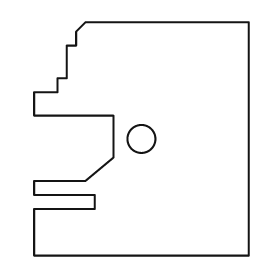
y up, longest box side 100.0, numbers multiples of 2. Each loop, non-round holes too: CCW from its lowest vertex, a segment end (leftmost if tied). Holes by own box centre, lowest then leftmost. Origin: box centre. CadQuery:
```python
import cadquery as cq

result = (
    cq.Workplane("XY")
    .moveTo(-46.0, -50.0)
    .lineTo(46.0, -50.0)
    .lineTo(46.0, 50.0)
    .lineTo(-24.0, 50.0)
    .lineTo(-28.0, 46.0)
    .lineTo(-28.0, 40.0)
    .lineTo(-32.0, 40.0)
    .lineTo(-32.0, 26.0)
    .lineTo(-36.0, 26.0)
    .lineTo(-36.0, 20.0)
    .lineTo(-46.0, 20.0)
    .lineTo(-46.0, 10.0)
    .lineTo(-12.0, 10.0)
    .lineTo(-12.0, -8.0)
    .lineTo(-24.0, -18.0)
    .lineTo(-46.0, -18.0)
    .lineTo(-46.0, -24.0)
    .lineTo(-20.0, -24.0)
    .lineTo(-20.0, -30.0)
    .lineTo(-46.0, -30.0)
    .close()
    .moveTo(0.0, 0.0)
    .circle(6.0)
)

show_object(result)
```